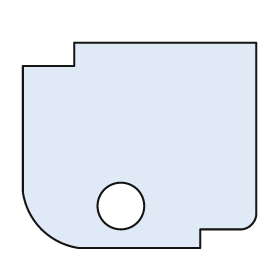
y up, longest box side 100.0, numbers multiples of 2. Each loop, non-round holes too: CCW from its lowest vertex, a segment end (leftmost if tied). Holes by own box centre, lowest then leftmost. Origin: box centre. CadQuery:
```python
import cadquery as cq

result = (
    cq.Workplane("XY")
    .moveTo(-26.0, -44.0)
    .lineTo(26.0, -44.0)
    .lineTo(26.0, -36.0)
    .lineTo(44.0, -36.0)
    .threePointArc((48.0, -34.0), (50.0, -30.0))
    .lineTo(50.0, 44.0)
    .lineTo(-28.0, 44.0)
    .lineTo(-28.0, 34.0)
    .lineTo(-50.0, 34.0)
    .lineTo(-50.0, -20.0)
    .threePointArc((-42.0, -36.0), (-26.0, -44.0))
    .close()
    .moveTo(-8.0, -26.0)
    .circle(10.0)
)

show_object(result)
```